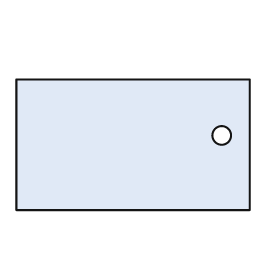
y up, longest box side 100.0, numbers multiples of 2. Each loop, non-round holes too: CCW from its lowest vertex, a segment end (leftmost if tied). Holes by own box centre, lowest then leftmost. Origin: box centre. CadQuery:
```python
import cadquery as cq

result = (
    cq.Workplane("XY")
    .moveTo(-50.0, -28.0)
    .lineTo(50.0, -28.0)
    .lineTo(50.0, 28.0)
    .lineTo(-50.0, 28.0)
    .close()
    .moveTo(38.0, 4.0)
    .circle(4.0)
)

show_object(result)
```